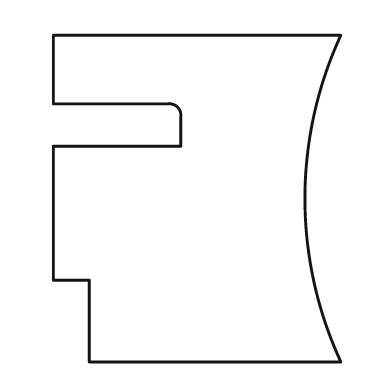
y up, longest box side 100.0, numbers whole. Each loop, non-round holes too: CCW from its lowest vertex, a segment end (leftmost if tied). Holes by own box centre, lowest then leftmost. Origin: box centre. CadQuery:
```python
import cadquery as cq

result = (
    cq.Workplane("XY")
    .moveTo(-33.0, -50.0)
    .lineTo(44.0, -50.0)
    .threePointArc((33.0, 0.0), (44.0, 50.0))
    .lineTo(-44.0, 50.0)
    .lineTo(-44.0, 29.0)
    .lineTo(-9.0, 29.0)
    .threePointArc((-6.0, 28.0), (-5.0, 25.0))
    .lineTo(-5.0, 16.0)
    .lineTo(-44.0, 16.0)
    .lineTo(-44.0, -25.0)
    .lineTo(-33.0, -25.0)
    .close()
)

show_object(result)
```